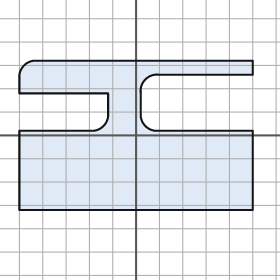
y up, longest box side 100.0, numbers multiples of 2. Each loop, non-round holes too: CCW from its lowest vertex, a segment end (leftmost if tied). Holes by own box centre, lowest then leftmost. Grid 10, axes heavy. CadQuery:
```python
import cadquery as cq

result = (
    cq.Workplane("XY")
    .moveTo(-50.0, -32.0)
    .lineTo(50.0, -32.0)
    .lineTo(50.0, 2.0)
    .lineTo(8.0, 2.0)
    .threePointArc((4.0, 4.0), (2.0, 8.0))
    .lineTo(2.0, 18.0)
    .threePointArc((4.0, 24.0), (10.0, 26.0))
    .lineTo(50.0, 26.0)
    .lineTo(50.0, 32.0)
    .lineTo(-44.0, 32.0)
    .threePointArc((-48.0, 30.0), (-50.0, 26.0))
    .lineTo(-50.0, 18.0)
    .lineTo(-12.0, 18.0)
    .lineTo(-12.0, 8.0)
    .threePointArc((-14.0, 4.0), (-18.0, 2.0))
    .lineTo(-50.0, 2.0)
    .close()
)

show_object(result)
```